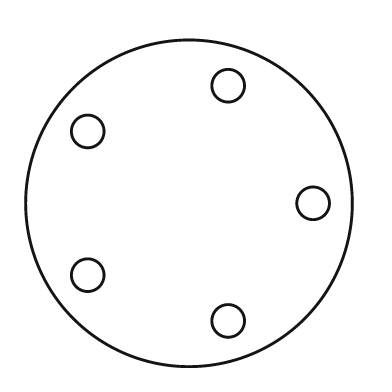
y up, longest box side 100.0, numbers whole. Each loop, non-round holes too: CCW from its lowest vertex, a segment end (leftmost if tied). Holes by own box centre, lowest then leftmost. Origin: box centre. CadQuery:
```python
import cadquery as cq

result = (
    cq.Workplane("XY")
    .moveTo(0.0, 0.0)
    .circle(50.0)
    .moveTo(12.0, -36.0)
    .circle(5.0)
    .moveTo(-31.0, -22.0)
    .circle(5.0)
    .moveTo(38.0, 0.0)
    .circle(5.0)
    .moveTo(-31.0, 22.0)
    .circle(5.0)
    .moveTo(12.0, 36.0)
    .circle(5.0)
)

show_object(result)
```